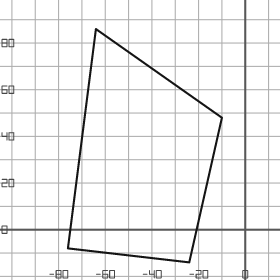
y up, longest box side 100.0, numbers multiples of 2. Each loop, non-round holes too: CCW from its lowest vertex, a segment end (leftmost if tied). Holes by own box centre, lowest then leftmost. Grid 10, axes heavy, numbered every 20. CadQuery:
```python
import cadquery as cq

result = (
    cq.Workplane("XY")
    .moveTo(-24.0, -14.0)
    .lineTo(-10.0, 48.0)
    .lineTo(-64.0, 86.0)
    .lineTo(-76.0, -8.0)
    .close()
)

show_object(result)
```